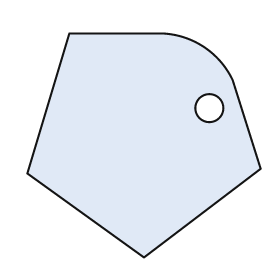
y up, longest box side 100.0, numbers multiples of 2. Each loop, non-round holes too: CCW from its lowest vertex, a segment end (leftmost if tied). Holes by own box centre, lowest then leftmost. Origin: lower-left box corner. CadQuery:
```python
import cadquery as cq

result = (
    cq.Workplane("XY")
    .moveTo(50.0, 0.0)
    .lineTo(100.0, 38.0)
    .lineTo(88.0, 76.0)
    .threePointArc((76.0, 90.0), (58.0, 96.0))
    .lineTo(18.0, 96.0)
    .lineTo(0.0, 36.0)
    .close()
    .moveTo(78.0, 64.0)
    .circle(6.0)
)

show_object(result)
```